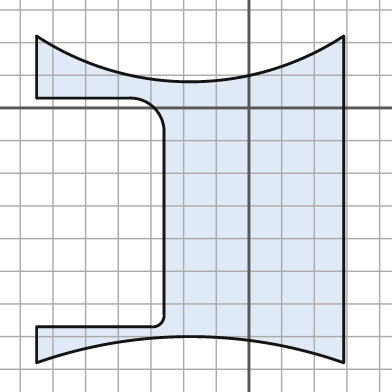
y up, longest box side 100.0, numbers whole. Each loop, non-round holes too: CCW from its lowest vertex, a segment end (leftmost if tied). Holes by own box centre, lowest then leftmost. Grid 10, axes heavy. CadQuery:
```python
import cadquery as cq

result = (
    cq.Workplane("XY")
    .moveTo(-65.0, -78.0)
    .threePointArc((-18.0, -70.0), (29.0, -78.0))
    .lineTo(29.0, 22.0)
    .threePointArc((-18.0, 8.0), (-65.0, 22.0))
    .lineTo(-65.0, 3.0)
    .lineTo(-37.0, 3.0)
    .threePointArc((-29.0, 0.0), (-26.0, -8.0))
    .lineTo(-26.0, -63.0)
    .threePointArc((-27.0, -66.0), (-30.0, -67.0))
    .lineTo(-65.0, -67.0)
    .close()
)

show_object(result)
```